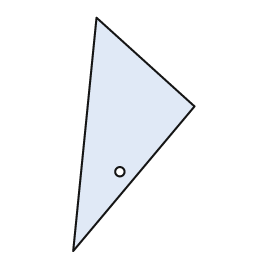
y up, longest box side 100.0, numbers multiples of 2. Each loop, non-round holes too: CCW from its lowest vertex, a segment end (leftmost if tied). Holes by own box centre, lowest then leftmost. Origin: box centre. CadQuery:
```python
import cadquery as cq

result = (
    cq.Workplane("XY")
    .moveTo(-26.0, -50.0)
    .lineTo(26.0, 12.0)
    .lineTo(-16.0, 50.0)
    .close()
    .moveTo(-6.0, -16.0)
    .circle(2.0)
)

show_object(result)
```